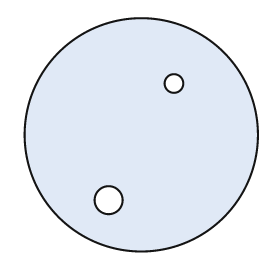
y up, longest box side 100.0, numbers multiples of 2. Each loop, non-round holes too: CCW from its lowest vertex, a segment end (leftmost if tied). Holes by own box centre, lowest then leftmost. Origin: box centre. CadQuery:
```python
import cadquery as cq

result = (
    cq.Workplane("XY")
    .moveTo(0.0, 0.0)
    .circle(50.0)
    .moveTo(-14.0, -28.0)
    .circle(6.0)
    .moveTo(14.0, 22.0)
    .circle(4.0)
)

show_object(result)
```